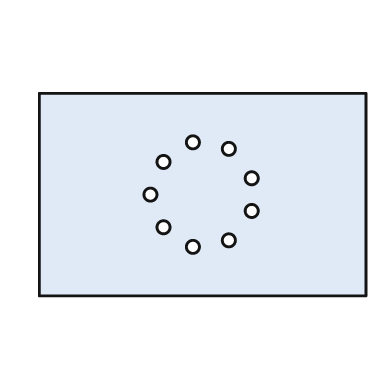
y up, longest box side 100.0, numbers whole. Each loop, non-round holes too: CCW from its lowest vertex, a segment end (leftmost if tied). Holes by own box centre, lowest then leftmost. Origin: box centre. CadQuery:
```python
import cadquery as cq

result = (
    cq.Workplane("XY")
    .moveTo(-50.0, -31.0)
    .lineTo(50.0, -31.0)
    .lineTo(50.0, 31.0)
    .lineTo(-50.0, 31.0)
    .close()
    .moveTo(-3.0, -16.0)
    .circle(2.0)
    .moveTo(8.0, -14.0)
    .circle(2.0)
    .moveTo(-12.0, -10.0)
    .circle(2.0)
    .moveTo(15.0, -5.0)
    .circle(2.0)
    .moveTo(-16.0, 0.0)
    .circle(2.0)
    .moveTo(15.0, 5.0)
    .circle(2.0)
    .moveTo(-12.0, 10.0)
    .circle(2.0)
    .moveTo(8.0, 14.0)
    .circle(2.0)
    .moveTo(-3.0, 16.0)
    .circle(2.0)
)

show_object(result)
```